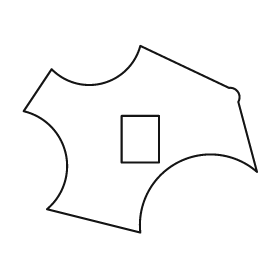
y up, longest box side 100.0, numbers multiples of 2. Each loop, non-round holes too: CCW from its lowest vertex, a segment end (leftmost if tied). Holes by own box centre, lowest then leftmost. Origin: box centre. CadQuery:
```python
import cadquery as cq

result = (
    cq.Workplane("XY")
    .moveTo(0.0, -40.0)
    .threePointArc((16.0, -10.0), (50.0, -14.0))
    .lineTo(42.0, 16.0)
    .threePointArc((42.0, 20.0), (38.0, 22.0))
    .lineTo(0.0, 40.0)
    .threePointArc((-16.0, 24.0), (-38.0, 30.0))
    .lineTo(-50.0, 12.0)
    .threePointArc((-32.0, -6.0), (-40.0, -30.0))
    .close()
    .moveTo(-8.0, -10.0)
    .lineTo(8.0, -10.0)
    .lineTo(8.0, 10.0)
    .lineTo(-8.0, 10.0)
    .close()
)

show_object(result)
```